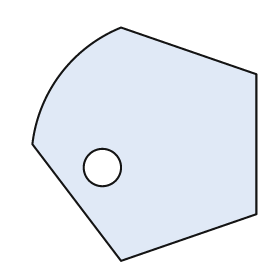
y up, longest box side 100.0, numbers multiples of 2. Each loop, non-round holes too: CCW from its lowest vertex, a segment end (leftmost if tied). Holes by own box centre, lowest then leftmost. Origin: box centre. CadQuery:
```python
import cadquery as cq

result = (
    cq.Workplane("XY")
    .moveTo(-10.0, -50.0)
    .lineTo(48.0, -30.0)
    .lineTo(48.0, 30.0)
    .lineTo(-10.0, 50.0)
    .threePointArc((-36.0, 30.0), (-48.0, 0.0))
    .close()
    .moveTo(-18.0, -10.0)
    .circle(8.0)
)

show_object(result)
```